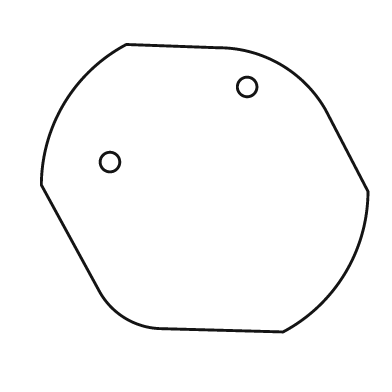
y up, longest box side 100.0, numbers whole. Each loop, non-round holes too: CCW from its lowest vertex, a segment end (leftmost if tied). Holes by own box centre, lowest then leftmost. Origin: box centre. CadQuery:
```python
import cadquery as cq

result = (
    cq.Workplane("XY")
    .moveTo(24.0, -44.0)
    .threePointArc((43.0, -26.0), (50.0, -1.0))
    .lineTo(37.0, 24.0)
    .threePointArc((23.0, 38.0), (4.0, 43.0))
    .lineTo(-24.0, 44.0)
    .threePointArc((-43.0, 26.0), (-50.0, 1.0))
    .lineTo(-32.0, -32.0)
    .threePointArc((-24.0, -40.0), (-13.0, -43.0))
    .close()
    .moveTo(-29.0, 8.0)
    .circle(3.0)
    .moveTo(13.0, 31.0)
    .circle(3.0)
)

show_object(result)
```